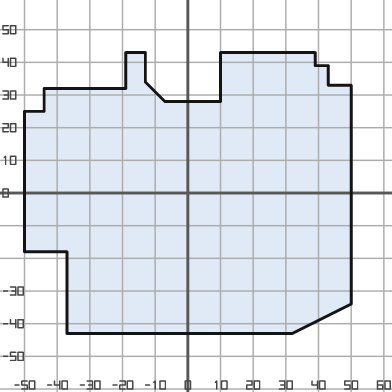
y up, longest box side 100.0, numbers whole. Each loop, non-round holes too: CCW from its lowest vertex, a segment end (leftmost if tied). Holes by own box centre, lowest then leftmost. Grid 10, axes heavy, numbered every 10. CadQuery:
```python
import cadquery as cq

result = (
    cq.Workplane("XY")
    .moveTo(-37.0, -43.0)
    .lineTo(32.0, -43.0)
    .lineTo(50.0, -34.0)
    .lineTo(50.0, 33.0)
    .lineTo(43.0, 33.0)
    .lineTo(43.0, 39.0)
    .lineTo(39.0, 39.0)
    .lineTo(39.0, 43.0)
    .lineTo(10.0, 43.0)
    .lineTo(10.0, 28.0)
    .lineTo(-7.0, 28.0)
    .lineTo(-13.0, 34.0)
    .lineTo(-13.0, 43.0)
    .lineTo(-19.0, 43.0)
    .lineTo(-19.0, 32.0)
    .lineTo(-44.0, 32.0)
    .lineTo(-44.0, 25.0)
    .lineTo(-50.0, 25.0)
    .lineTo(-50.0, -18.0)
    .lineTo(-37.0, -18.0)
    .close()
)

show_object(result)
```